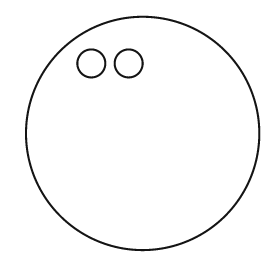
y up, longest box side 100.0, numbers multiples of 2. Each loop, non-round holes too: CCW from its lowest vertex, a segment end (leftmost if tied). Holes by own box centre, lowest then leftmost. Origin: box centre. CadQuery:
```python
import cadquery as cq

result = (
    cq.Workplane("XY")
    .moveTo(0.0, 0.0)
    .circle(50.0)
    .moveTo(-22.0, 30.0)
    .circle(6.0)
    .moveTo(-6.0, 30.0)
    .circle(6.0)
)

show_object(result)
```